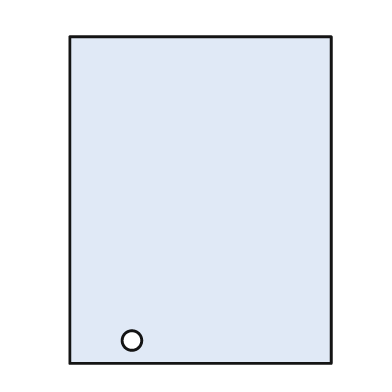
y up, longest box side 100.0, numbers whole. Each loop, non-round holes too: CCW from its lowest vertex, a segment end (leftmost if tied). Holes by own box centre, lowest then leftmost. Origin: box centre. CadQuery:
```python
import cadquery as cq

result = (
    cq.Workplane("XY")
    .moveTo(-40.0, -50.0)
    .lineTo(40.0, -50.0)
    .lineTo(40.0, 50.0)
    .lineTo(-40.0, 50.0)
    .close()
    .moveTo(-21.0, -43.0)
    .circle(3.0)
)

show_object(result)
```